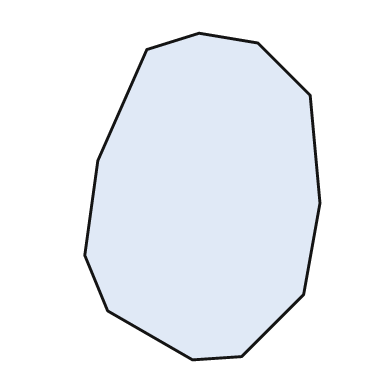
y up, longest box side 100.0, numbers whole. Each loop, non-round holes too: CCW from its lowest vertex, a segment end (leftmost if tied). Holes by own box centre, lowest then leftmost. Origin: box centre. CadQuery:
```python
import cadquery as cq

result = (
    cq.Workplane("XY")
    .moveTo(-3.0, -50.0)
    .lineTo(12.0, -49.0)
    .lineTo(31.0, -30.0)
    .lineTo(36.0, -2.0)
    .lineTo(33.0, 31.0)
    .lineTo(17.0, 47.0)
    .lineTo(-1.0, 50.0)
    .lineTo(-17.0, 45.0)
    .lineTo(-32.0, 11.0)
    .lineTo(-36.0, -18.0)
    .lineTo(-29.0, -35.0)
    .close()
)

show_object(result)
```